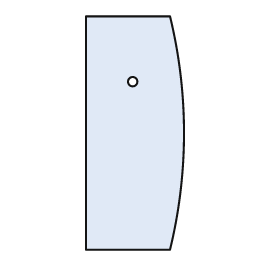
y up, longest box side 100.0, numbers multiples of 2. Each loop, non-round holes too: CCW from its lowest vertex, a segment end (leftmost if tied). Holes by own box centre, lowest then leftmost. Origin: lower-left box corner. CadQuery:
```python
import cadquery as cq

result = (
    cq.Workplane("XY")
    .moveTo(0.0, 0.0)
    .lineTo(36.0, 0.0)
    .threePointArc((42.0, 50.0), (36.0, 100.0))
    .lineTo(0.0, 100.0)
    .close()
    .moveTo(20.0, 72.0)
    .circle(2.0)
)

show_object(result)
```